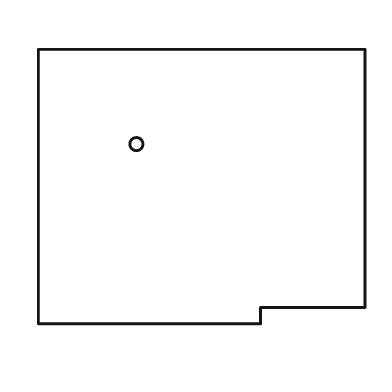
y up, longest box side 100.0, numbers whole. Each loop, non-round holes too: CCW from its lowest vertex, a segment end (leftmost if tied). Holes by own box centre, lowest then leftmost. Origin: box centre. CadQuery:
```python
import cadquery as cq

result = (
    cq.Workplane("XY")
    .moveTo(-50.0, -42.0)
    .lineTo(18.0, -42.0)
    .lineTo(18.0, -37.0)
    .lineTo(50.0, -37.0)
    .lineTo(50.0, 42.0)
    .lineTo(-50.0, 42.0)
    .close()
    .moveTo(-20.0, 13.0)
    .circle(2.0)
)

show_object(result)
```